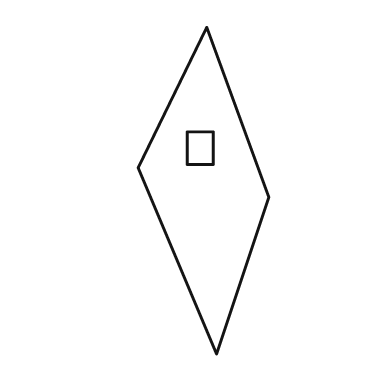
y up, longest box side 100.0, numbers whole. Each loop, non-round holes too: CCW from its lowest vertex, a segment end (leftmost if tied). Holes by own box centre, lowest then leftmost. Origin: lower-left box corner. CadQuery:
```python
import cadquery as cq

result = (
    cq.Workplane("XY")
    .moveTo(24.0, 0.0)
    .lineTo(40.0, 48.0)
    .lineTo(21.0, 100.0)
    .lineTo(0.0, 57.0)
    .close()
    .moveTo(15.0, 58.0)
    .lineTo(23.0, 58.0)
    .lineTo(23.0, 68.0)
    .lineTo(15.0, 68.0)
    .close()
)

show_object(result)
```